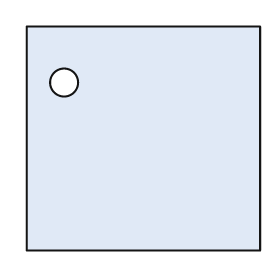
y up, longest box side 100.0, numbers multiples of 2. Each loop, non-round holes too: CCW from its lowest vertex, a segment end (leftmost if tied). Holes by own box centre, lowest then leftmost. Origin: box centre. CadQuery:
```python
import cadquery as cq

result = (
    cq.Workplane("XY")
    .moveTo(-50.0, -48.0)
    .lineTo(50.0, -48.0)
    .lineTo(50.0, 48.0)
    .lineTo(-50.0, 48.0)
    .close()
    .moveTo(-34.0, 24.0)
    .circle(6.0)
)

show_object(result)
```